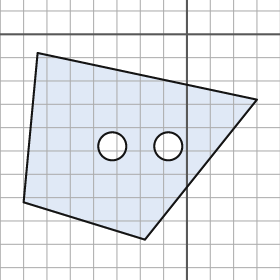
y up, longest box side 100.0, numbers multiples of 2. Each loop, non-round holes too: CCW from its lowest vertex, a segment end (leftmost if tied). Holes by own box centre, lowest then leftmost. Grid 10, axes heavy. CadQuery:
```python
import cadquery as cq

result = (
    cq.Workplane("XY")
    .moveTo(-18.0, -88.0)
    .lineTo(30.0, -28.0)
    .lineTo(-64.0, -8.0)
    .lineTo(-70.0, -72.0)
    .close()
    .moveTo(-32.0, -48.0)
    .circle(6.0)
    .moveTo(-8.0, -48.0)
    .circle(6.0)
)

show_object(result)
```